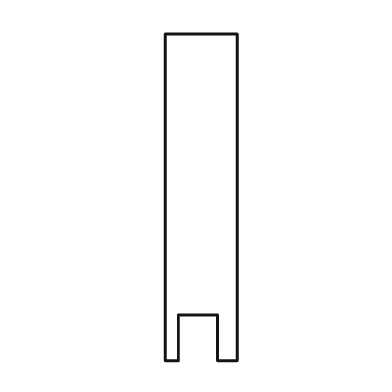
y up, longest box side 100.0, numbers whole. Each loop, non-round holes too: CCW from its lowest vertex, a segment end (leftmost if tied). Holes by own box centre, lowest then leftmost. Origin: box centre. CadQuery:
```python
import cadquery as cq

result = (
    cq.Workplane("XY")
    .moveTo(-11.0, -50.0)
    .lineTo(-7.0, -50.0)
    .lineTo(-7.0, -36.0)
    .lineTo(5.0, -36.0)
    .lineTo(5.0, -50.0)
    .lineTo(11.0, -50.0)
    .lineTo(11.0, 50.0)
    .lineTo(-11.0, 50.0)
    .close()
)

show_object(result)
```